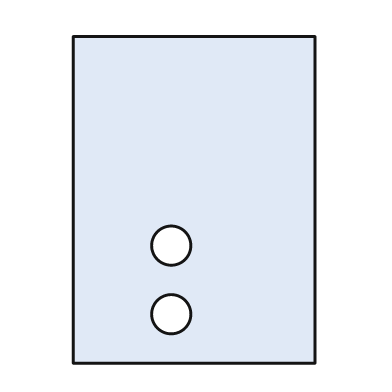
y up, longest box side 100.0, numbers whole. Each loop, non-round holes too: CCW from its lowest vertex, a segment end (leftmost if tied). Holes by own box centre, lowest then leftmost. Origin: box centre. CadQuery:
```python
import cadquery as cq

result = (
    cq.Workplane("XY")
    .moveTo(-37.0, -50.0)
    .lineTo(37.0, -50.0)
    .lineTo(37.0, 50.0)
    .lineTo(-37.0, 50.0)
    .close()
    .moveTo(-7.0, -35.0)
    .circle(6.0)
    .moveTo(-7.0, -14.0)
    .circle(6.0)
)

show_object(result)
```